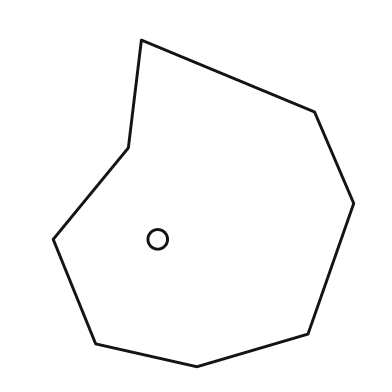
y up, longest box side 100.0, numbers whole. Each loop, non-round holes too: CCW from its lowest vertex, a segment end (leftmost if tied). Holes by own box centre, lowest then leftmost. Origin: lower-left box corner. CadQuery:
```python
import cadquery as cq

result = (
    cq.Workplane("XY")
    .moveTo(44.0, 0.0)
    .lineTo(78.0, 10.0)
    .lineTo(92.0, 50.0)
    .lineTo(80.0, 78.0)
    .lineTo(27.0, 100.0)
    .lineTo(23.0, 67.0)
    .lineTo(0.0, 39.0)
    .lineTo(13.0, 7.0)
    .close()
    .moveTo(32.0, 39.0)
    .circle(3.0)
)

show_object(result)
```